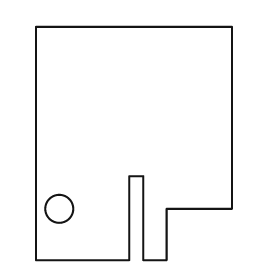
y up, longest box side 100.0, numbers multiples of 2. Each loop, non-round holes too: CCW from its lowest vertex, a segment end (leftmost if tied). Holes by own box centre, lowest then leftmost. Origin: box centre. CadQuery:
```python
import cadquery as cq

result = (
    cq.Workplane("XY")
    .moveTo(-42.0, -50.0)
    .lineTo(-2.0, -50.0)
    .lineTo(-2.0, -14.0)
    .lineTo(4.0, -14.0)
    .lineTo(4.0, -50.0)
    .lineTo(14.0, -50.0)
    .lineTo(14.0, -28.0)
    .lineTo(42.0, -28.0)
    .lineTo(42.0, 50.0)
    .lineTo(-42.0, 50.0)
    .close()
    .moveTo(-32.0, -28.0)
    .circle(6.0)
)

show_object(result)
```